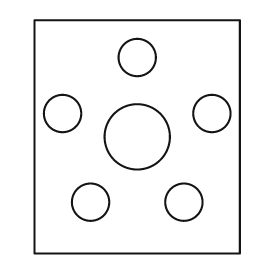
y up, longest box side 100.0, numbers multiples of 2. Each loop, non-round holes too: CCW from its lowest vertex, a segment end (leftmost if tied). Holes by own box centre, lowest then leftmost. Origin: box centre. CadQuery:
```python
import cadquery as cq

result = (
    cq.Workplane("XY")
    .moveTo(-44.0, -50.0)
    .lineTo(44.0, -50.0)
    .lineTo(44.0, 50.0)
    .lineTo(-44.0, 50.0)
    .close()
    .moveTo(-20.0, -28.0)
    .circle(8.0)
    .moveTo(20.0, -28.0)
    .circle(8.0)
    .moveTo(0.0, 0.0)
    .circle(14.0)
    .moveTo(-32.0, 10.0)
    .circle(8.0)
    .moveTo(32.0, 10.0)
    .circle(8.0)
    .moveTo(0.0, 34.0)
    .circle(8.0)
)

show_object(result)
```